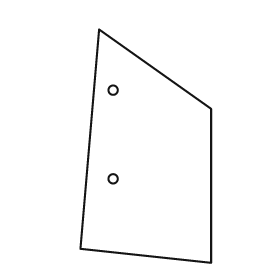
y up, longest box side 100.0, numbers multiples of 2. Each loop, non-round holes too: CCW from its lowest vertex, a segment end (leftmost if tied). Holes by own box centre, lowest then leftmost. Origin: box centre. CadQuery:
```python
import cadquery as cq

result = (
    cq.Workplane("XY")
    .moveTo(28.0, -50.0)
    .lineTo(28.0, 16.0)
    .lineTo(-20.0, 50.0)
    .lineTo(-28.0, -44.0)
    .close()
    .moveTo(-14.0, -14.0)
    .circle(2.0)
    .moveTo(-14.0, 24.0)
    .circle(2.0)
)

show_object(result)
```